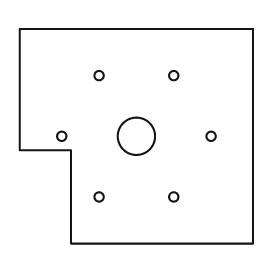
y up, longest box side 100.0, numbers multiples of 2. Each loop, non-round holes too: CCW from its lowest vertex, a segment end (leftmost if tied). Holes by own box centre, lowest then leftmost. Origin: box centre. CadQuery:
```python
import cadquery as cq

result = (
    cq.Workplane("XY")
    .moveTo(-28.0, -46.0)
    .lineTo(50.0, -46.0)
    .lineTo(50.0, 46.0)
    .lineTo(-50.0, 46.0)
    .lineTo(-50.0, -6.0)
    .lineTo(-28.0, -6.0)
    .close()
    .moveTo(-16.0, -26.0)
    .circle(2.0)
    .moveTo(16.0, -26.0)
    .circle(2.0)
    .moveTo(-32.0, 0.0)
    .circle(2.0)
    .moveTo(0.0, 0.0)
    .circle(8.0)
    .moveTo(32.0, 0.0)
    .circle(2.0)
    .moveTo(-16.0, 26.0)
    .circle(2.0)
    .moveTo(16.0, 26.0)
    .circle(2.0)
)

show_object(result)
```